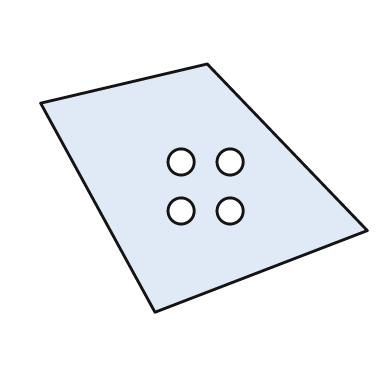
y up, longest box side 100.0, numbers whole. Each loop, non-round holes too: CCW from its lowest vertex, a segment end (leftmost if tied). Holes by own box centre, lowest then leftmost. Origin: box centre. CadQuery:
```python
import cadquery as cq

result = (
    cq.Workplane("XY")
    .moveTo(-15.0, -38.0)
    .lineTo(50.0, -13.0)
    .lineTo(1.0, 38.0)
    .lineTo(-50.0, 26.0)
    .close()
    .moveTo(-7.0, -7.0)
    .circle(4.0)
    .moveTo(8.0, -7.0)
    .circle(4.0)
    .moveTo(-7.0, 8.0)
    .circle(4.0)
    .moveTo(8.0, 8.0)
    .circle(4.0)
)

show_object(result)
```